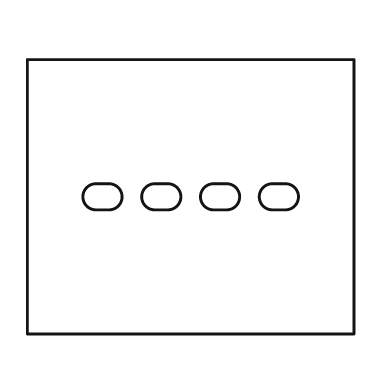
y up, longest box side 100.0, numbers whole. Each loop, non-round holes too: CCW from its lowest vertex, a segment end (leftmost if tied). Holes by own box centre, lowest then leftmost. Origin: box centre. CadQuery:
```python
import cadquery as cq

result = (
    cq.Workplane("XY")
    .moveTo(-50.0, -42.0)
    .lineTo(50.0, -42.0)
    .lineTo(50.0, 42.0)
    .lineTo(-50.0, 42.0)
    .close()
    .moveTo(-29.0, -4.0)
    .lineTo(-25.0, -4.0)
    .threePointArc((-21.0, 0.0), (-25.0, 4.0))
    .lineTo(-29.0, 4.0)
    .threePointArc((-33.0, 0.0), (-29.0, -4.0))
    .close()
    .moveTo(-11.0, -4.0)
    .lineTo(-7.0, -4.0)
    .threePointArc((-3.0, 0.0), (-7.0, 4.0))
    .lineTo(-11.0, 4.0)
    .threePointArc((-15.0, 0.0), (-11.0, -4.0))
    .close()
    .moveTo(7.0, -4.0)
    .lineTo(11.0, -4.0)
    .threePointArc((15.0, 0.0), (11.0, 4.0))
    .lineTo(7.0, 4.0)
    .threePointArc((3.0, 0.0), (7.0, -4.0))
    .close()
    .moveTo(25.0, -4.0)
    .lineTo(29.0, -4.0)
    .threePointArc((33.0, 0.0), (29.0, 4.0))
    .lineTo(25.0, 4.0)
    .threePointArc((21.0, 0.0), (25.0, -4.0))
    .close()
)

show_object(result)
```